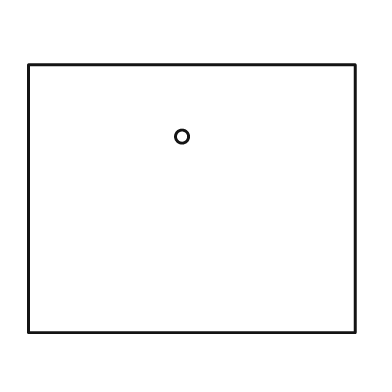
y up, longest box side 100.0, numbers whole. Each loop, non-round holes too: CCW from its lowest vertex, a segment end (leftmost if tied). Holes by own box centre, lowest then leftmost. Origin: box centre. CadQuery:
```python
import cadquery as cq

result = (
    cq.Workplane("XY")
    .moveTo(-50.0, -41.0)
    .lineTo(50.0, -41.0)
    .lineTo(50.0, 41.0)
    .lineTo(-50.0, 41.0)
    .close()
    .moveTo(-3.0, 19.0)
    .circle(2.0)
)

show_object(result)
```